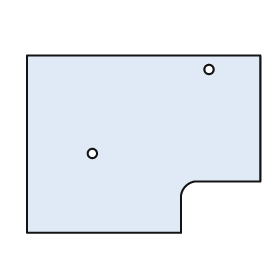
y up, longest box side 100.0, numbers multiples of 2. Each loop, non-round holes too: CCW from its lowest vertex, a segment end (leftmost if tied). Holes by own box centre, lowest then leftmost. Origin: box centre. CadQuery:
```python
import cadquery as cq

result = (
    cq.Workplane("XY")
    .moveTo(-50.0, -38.0)
    .lineTo(16.0, -38.0)
    .lineTo(16.0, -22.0)
    .threePointArc((18.0, -18.0), (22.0, -16.0))
    .lineTo(50.0, -16.0)
    .lineTo(50.0, 38.0)
    .lineTo(-50.0, 38.0)
    .close()
    .moveTo(-22.0, -4.0)
    .circle(2.0)
    .moveTo(28.0, 32.0)
    .circle(2.0)
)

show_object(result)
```